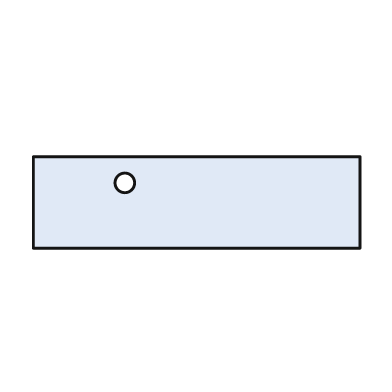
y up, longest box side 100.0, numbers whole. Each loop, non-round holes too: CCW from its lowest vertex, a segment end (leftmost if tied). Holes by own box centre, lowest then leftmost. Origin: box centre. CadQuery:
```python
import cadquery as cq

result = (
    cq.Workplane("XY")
    .moveTo(-50.0, -14.0)
    .lineTo(50.0, -14.0)
    .lineTo(50.0, 14.0)
    .lineTo(-50.0, 14.0)
    .close()
    .moveTo(-22.0, 6.0)
    .circle(3.0)
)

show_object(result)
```